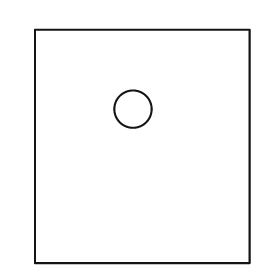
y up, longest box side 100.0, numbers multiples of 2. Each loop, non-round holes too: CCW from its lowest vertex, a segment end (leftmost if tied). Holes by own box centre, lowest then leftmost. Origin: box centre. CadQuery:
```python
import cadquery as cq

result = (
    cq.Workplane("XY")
    .moveTo(-46.0, -50.0)
    .lineTo(46.0, -50.0)
    .lineTo(46.0, 50.0)
    .lineTo(-46.0, 50.0)
    .close()
    .moveTo(-4.0, 16.0)
    .circle(8.0)
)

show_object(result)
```